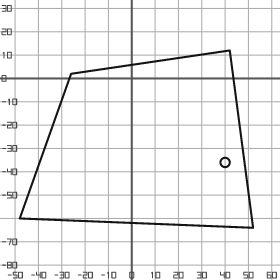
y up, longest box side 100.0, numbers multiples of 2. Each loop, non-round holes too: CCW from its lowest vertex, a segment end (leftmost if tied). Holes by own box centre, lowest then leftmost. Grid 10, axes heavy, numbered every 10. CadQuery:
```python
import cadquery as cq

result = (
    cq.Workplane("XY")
    .moveTo(52.0, -64.0)
    .lineTo(42.0, 12.0)
    .lineTo(-26.0, 2.0)
    .lineTo(-48.0, -60.0)
    .close()
    .moveTo(40.0, -36.0)
    .circle(2.0)
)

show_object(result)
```